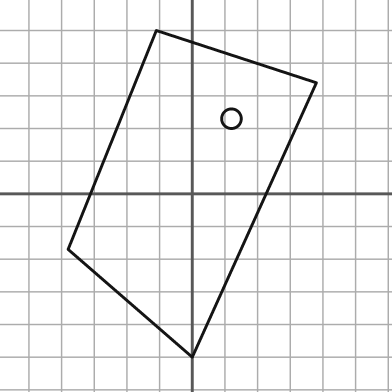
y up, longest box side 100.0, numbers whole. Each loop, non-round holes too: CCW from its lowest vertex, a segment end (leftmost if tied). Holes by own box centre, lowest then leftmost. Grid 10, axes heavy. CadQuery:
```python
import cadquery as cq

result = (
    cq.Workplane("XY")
    .moveTo(0.0, -50.0)
    .lineTo(38.0, 34.0)
    .lineTo(-11.0, 50.0)
    .lineTo(-38.0, -17.0)
    .close()
    .moveTo(12.0, 23.0)
    .circle(3.0)
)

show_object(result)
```